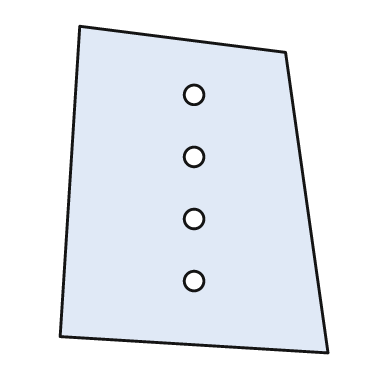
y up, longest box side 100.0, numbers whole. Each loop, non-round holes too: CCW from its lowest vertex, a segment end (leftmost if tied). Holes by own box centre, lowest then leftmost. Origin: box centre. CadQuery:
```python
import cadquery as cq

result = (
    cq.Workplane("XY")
    .moveTo(41.0, -50.0)
    .lineTo(28.0, 42.0)
    .lineTo(-35.0, 50.0)
    .lineTo(-41.0, -45.0)
    .close()
    .moveTo(0.0, -28.0)
    .circle(3.0)
    .moveTo(0.0, -9.0)
    .circle(3.0)
    .moveTo(0.0, 10.0)
    .circle(3.0)
    .moveTo(0.0, 29.0)
    .circle(3.0)
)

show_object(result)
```